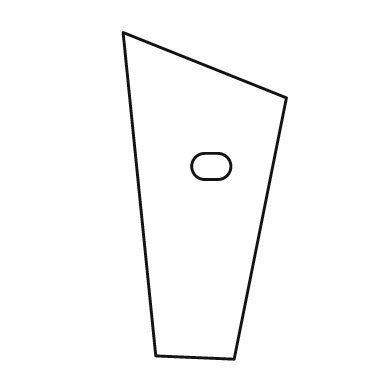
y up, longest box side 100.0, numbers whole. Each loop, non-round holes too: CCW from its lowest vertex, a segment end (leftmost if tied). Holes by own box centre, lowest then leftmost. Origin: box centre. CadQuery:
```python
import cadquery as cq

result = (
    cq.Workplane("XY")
    .moveTo(9.0, -50.0)
    .lineTo(25.0, 30.0)
    .lineTo(-25.0, 50.0)
    .lineTo(-15.0, -49.0)
    .close()
    .moveTo(0.0, 5.0)
    .lineTo(4.0, 5.0)
    .threePointArc((8.0, 9.0), (4.0, 13.0))
    .lineTo(0.0, 13.0)
    .threePointArc((-4.0, 9.0), (0.0, 5.0))
    .close()
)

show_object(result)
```